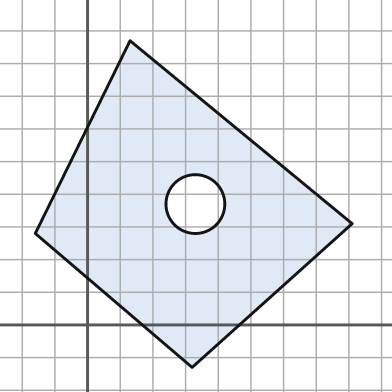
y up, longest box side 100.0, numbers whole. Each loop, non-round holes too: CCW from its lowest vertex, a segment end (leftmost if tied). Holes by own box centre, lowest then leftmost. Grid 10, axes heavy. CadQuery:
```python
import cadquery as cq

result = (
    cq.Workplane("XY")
    .moveTo(32.0, -13.0)
    .lineTo(81.0, 31.0)
    .lineTo(13.0, 87.0)
    .lineTo(-16.0, 28.0)
    .close()
    .moveTo(33.0, 37.0)
    .circle(9.0)
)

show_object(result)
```